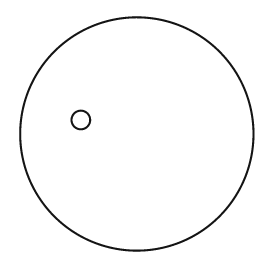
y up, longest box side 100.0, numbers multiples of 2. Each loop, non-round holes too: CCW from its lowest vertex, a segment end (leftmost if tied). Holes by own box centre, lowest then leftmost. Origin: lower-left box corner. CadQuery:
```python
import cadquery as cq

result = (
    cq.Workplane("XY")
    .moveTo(50.0, 50.0)
    .circle(50.0)
    .moveTo(26.0, 56.0)
    .circle(4.0)
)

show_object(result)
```